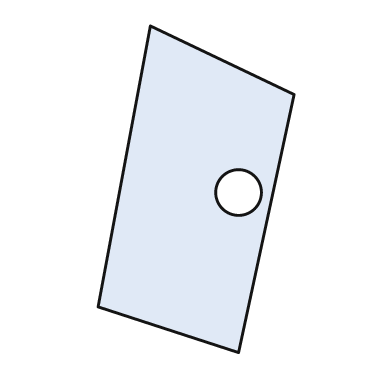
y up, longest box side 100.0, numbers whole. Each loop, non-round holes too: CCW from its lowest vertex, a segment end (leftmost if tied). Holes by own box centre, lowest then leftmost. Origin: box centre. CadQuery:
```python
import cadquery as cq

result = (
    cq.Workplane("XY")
    .moveTo(13.0, -50.0)
    .lineTo(30.0, 29.0)
    .lineTo(-14.0, 50.0)
    .lineTo(-30.0, -36.0)
    .close()
    .moveTo(13.0, -1.0)
    .circle(7.0)
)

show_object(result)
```